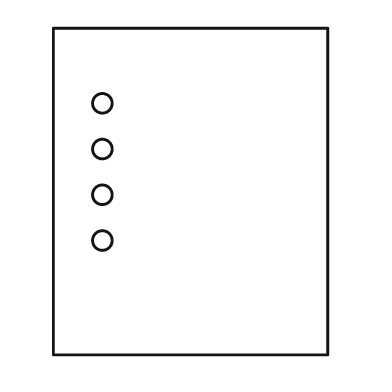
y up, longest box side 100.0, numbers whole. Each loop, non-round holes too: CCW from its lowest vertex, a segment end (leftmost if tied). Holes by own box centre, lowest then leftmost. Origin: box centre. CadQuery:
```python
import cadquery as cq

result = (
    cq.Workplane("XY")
    .moveTo(-42.0, -50.0)
    .lineTo(42.0, -50.0)
    .lineTo(42.0, 50.0)
    .lineTo(-42.0, 50.0)
    .close()
    .moveTo(-27.0, -15.0)
    .circle(3.0)
    .moveTo(-27.0, -1.0)
    .circle(3.0)
    .moveTo(-27.0, 13.0)
    .circle(3.0)
    .moveTo(-27.0, 27.0)
    .circle(3.0)
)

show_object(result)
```